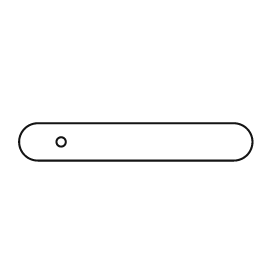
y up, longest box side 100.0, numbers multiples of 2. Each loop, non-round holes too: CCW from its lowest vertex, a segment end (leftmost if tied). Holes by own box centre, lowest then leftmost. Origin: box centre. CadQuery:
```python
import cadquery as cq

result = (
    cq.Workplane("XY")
    .moveTo(-42.0, -8.0)
    .lineTo(42.0, -8.0)
    .threePointArc((50.0, 0.0), (42.0, 8.0))
    .lineTo(-42.0, 8.0)
    .threePointArc((-50.0, 0.0), (-42.0, -8.0))
    .close()
    .moveTo(-32.0, 0.0)
    .circle(2.0)
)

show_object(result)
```